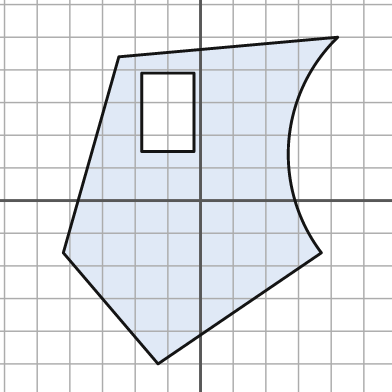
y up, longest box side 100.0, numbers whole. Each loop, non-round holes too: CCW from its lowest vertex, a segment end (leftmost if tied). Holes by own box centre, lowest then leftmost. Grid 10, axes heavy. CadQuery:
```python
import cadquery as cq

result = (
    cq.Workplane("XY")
    .moveTo(-13.0, -50.0)
    .lineTo(37.0, -16.0)
    .threePointArc((27.0, 18.0), (42.0, 50.0))
    .lineTo(-25.0, 44.0)
    .lineTo(-42.0, -16.0)
    .close()
    .moveTo(-18.0, 15.0)
    .lineTo(-2.0, 15.0)
    .lineTo(-2.0, 39.0)
    .lineTo(-18.0, 39.0)
    .close()
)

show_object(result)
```